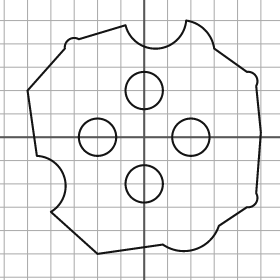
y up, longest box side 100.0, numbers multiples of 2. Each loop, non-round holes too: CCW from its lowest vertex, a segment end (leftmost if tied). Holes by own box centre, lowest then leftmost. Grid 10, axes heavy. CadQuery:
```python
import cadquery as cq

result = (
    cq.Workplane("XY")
    .moveTo(-20.0, -50.0)
    .lineTo(8.0, -46.0)
    .threePointArc((22.0, -48.0), (32.0, -38.0))
    .lineTo(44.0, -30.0)
    .threePointArc((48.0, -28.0), (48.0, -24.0))
    .lineTo(50.0, 2.0)
    .lineTo(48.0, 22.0)
    .threePointArc((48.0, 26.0), (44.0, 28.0))
    .lineTo(30.0, 38.0)
    .threePointArc((26.0, 46.0), (18.0, 50.0))
    .threePointArc((6.0, 38.0), (-8.0, 48.0))
    .lineTo(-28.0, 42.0)
    .threePointArc((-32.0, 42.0), (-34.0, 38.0))
    .lineTo(-50.0, 20.0)
    .lineTo(-46.0, -8.0)
    .threePointArc((-34.0, -18.0), (-40.0, -32.0))
    .close()
    .moveTo(0.0, -20.0)
    .circle(8.0)
    .moveTo(-20.0, 0.0)
    .circle(8.0)
    .moveTo(20.0, 0.0)
    .circle(8.0)
    .moveTo(0.0, 20.0)
    .circle(8.0)
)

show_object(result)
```